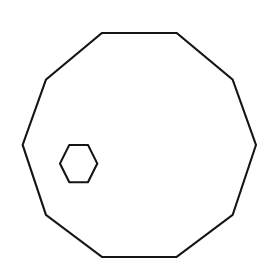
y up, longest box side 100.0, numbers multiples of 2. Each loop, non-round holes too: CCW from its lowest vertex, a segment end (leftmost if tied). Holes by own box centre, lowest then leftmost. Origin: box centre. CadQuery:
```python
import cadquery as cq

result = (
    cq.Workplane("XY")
    .moveTo(-16.0, -48.0)
    .lineTo(16.0, -48.0)
    .lineTo(40.0, -30.0)
    .lineTo(50.0, 0.0)
    .lineTo(40.0, 28.0)
    .lineTo(16.0, 48.0)
    .lineTo(-16.0, 48.0)
    .lineTo(-40.0, 28.0)
    .lineTo(-50.0, 0.0)
    .lineTo(-40.0, -30.0)
    .close()
    .moveTo(-30.0, -16.0)
    .lineTo(-22.0, -16.0)
    .lineTo(-18.0, -8.0)
    .lineTo(-22.0, 0.0)
    .lineTo(-30.0, 0.0)
    .lineTo(-34.0, -8.0)
    .close()
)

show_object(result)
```